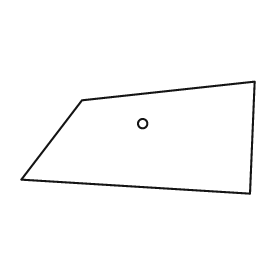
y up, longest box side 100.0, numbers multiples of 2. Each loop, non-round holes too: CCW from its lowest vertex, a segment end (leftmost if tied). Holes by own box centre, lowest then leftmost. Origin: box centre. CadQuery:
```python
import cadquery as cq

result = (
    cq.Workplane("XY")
    .moveTo(48.0, -24.0)
    .lineTo(50.0, 24.0)
    .lineTo(-24.0, 16.0)
    .lineTo(-50.0, -18.0)
    .close()
    .moveTo(2.0, 6.0)
    .circle(2.0)
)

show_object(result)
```